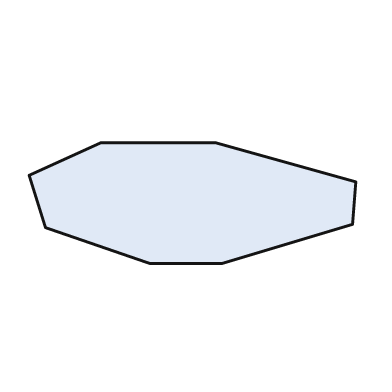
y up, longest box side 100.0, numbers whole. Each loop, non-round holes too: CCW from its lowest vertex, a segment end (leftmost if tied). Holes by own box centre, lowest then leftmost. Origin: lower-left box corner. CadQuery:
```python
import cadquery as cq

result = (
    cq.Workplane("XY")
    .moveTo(37.0, 0.0)
    .lineTo(59.0, 0.0)
    .lineTo(99.0, 12.0)
    .lineTo(100.0, 25.0)
    .lineTo(57.0, 37.0)
    .lineTo(22.0, 37.0)
    .lineTo(0.0, 27.0)
    .lineTo(5.0, 11.0)
    .close()
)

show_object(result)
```